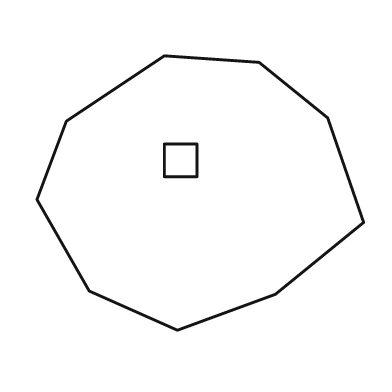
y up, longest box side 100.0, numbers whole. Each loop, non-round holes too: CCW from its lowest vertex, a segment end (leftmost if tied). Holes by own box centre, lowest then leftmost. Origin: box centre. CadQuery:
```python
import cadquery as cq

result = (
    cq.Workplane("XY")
    .moveTo(-7.0, -42.0)
    .lineTo(23.0, -31.0)
    .lineTo(50.0, -9.0)
    .lineTo(39.0, 23.0)
    .lineTo(18.0, 40.0)
    .lineTo(-11.0, 42.0)
    .lineTo(-41.0, 22.0)
    .lineTo(-50.0, -2.0)
    .lineTo(-34.0, -30.0)
    .close()
    .moveTo(-11.0, 5.0)
    .lineTo(-1.0, 5.0)
    .lineTo(-1.0, 15.0)
    .lineTo(-11.0, 15.0)
    .close()
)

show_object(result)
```